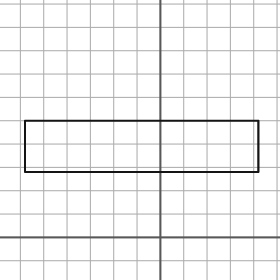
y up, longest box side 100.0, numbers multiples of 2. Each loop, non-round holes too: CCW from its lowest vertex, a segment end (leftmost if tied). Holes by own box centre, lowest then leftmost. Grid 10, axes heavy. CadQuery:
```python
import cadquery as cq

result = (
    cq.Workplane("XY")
    .moveTo(-58.0, 28.0)
    .lineTo(42.0, 28.0)
    .lineTo(42.0, 50.0)
    .lineTo(-58.0, 50.0)
    .close()
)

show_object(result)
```